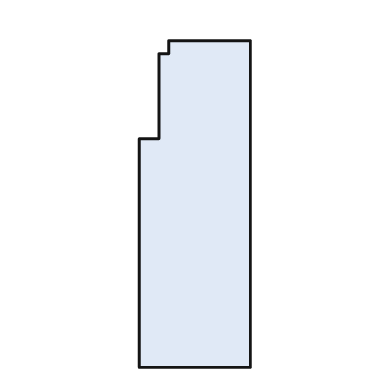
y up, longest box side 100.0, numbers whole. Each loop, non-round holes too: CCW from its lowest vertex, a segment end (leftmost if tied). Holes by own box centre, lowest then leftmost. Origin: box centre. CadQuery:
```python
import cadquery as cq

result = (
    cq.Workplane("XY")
    .moveTo(-17.0, -50.0)
    .lineTo(17.0, -50.0)
    .lineTo(17.0, 50.0)
    .lineTo(-8.0, 50.0)
    .lineTo(-8.0, 46.0)
    .lineTo(-11.0, 46.0)
    .lineTo(-11.0, 20.0)
    .lineTo(-17.0, 20.0)
    .close()
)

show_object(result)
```